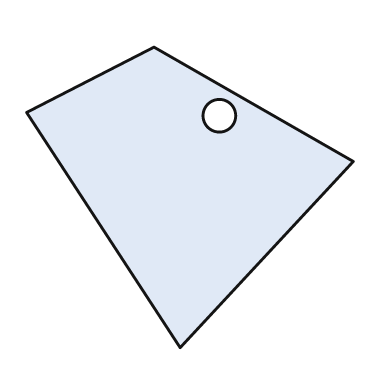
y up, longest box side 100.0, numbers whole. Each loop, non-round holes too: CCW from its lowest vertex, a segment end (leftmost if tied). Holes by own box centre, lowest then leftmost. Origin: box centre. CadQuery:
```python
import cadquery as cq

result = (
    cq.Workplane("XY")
    .moveTo(-3.0, -46.0)
    .lineTo(50.0, 11.0)
    .lineTo(-11.0, 46.0)
    .lineTo(-50.0, 26.0)
    .close()
    .moveTo(9.0, 25.0)
    .circle(5.0)
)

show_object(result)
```